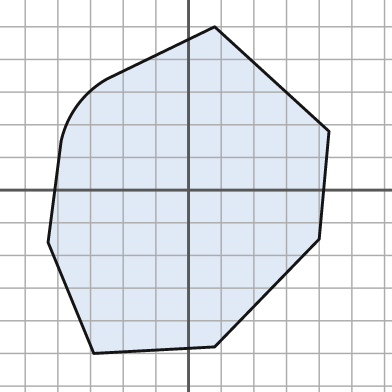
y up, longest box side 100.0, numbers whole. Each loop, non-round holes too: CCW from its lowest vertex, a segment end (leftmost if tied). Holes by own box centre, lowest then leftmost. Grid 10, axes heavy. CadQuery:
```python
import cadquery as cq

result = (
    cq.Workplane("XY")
    .moveTo(-29.0, -50.0)
    .lineTo(8.0, -48.0)
    .lineTo(40.0, -15.0)
    .lineTo(43.0, 18.0)
    .lineTo(8.0, 50.0)
    .lineTo(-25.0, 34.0)
    .threePointArc((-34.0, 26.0), (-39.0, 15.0))
    .lineTo(-43.0, -16.0)
    .close()
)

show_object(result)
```